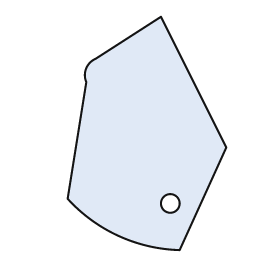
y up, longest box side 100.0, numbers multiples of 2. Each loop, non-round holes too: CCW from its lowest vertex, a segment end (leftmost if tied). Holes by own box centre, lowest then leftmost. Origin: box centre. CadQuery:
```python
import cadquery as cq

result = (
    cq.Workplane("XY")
    .moveTo(14.0, -50.0)
    .lineTo(34.0, -6.0)
    .lineTo(6.0, 50.0)
    .lineTo(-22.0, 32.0)
    .threePointArc((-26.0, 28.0), (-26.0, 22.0))
    .lineTo(-34.0, -28.0)
    .threePointArc((-12.0, -44.0), (14.0, -50.0))
    .close()
    .moveTo(10.0, -30.0)
    .circle(4.0)
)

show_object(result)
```